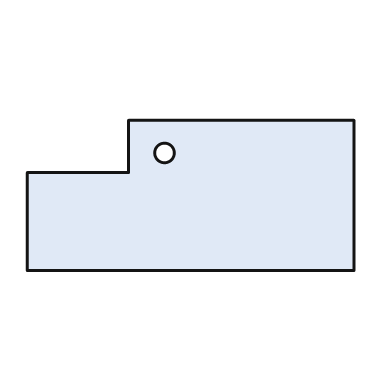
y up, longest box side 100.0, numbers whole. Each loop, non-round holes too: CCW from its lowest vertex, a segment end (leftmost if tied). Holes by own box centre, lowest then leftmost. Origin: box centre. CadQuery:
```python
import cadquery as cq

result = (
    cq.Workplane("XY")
    .moveTo(-50.0, -23.0)
    .lineTo(50.0, -23.0)
    .lineTo(50.0, 23.0)
    .lineTo(-19.0, 23.0)
    .lineTo(-19.0, 7.0)
    .lineTo(-50.0, 7.0)
    .close()
    .moveTo(-8.0, 13.0)
    .circle(3.0)
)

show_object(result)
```